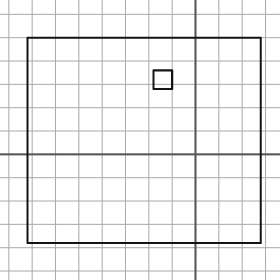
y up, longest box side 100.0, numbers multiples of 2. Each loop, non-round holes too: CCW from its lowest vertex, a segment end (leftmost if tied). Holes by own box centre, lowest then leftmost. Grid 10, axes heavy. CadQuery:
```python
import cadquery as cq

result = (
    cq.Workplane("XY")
    .moveTo(-72.0, -38.0)
    .lineTo(28.0, -38.0)
    .lineTo(28.0, 50.0)
    .lineTo(-72.0, 50.0)
    .close()
    .moveTo(-18.0, 28.0)
    .lineTo(-10.0, 28.0)
    .lineTo(-10.0, 36.0)
    .lineTo(-18.0, 36.0)
    .close()
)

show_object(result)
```